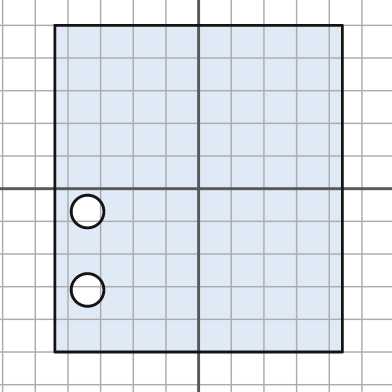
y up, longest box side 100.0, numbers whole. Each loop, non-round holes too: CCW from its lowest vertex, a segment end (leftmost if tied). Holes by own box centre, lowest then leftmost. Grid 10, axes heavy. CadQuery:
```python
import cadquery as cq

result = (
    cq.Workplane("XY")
    .moveTo(-44.0, -50.0)
    .lineTo(44.0, -50.0)
    .lineTo(44.0, 50.0)
    .lineTo(-44.0, 50.0)
    .close()
    .moveTo(-34.0, -31.0)
    .circle(5.0)
    .moveTo(-34.0, -7.0)
    .circle(5.0)
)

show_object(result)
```